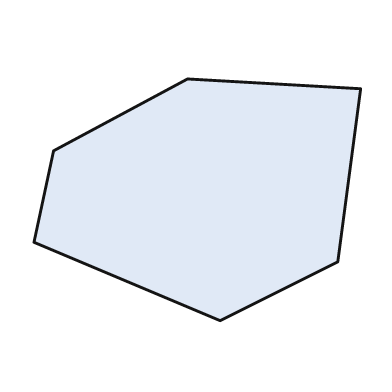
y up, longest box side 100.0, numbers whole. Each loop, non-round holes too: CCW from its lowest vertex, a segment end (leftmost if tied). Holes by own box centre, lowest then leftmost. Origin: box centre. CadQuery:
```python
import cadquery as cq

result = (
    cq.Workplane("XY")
    .moveTo(7.0, -37.0)
    .lineTo(43.0, -19.0)
    .lineTo(50.0, 34.0)
    .lineTo(-3.0, 37.0)
    .lineTo(-44.0, 15.0)
    .lineTo(-50.0, -13.0)
    .close()
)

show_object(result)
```